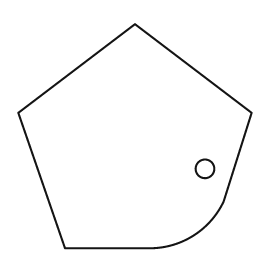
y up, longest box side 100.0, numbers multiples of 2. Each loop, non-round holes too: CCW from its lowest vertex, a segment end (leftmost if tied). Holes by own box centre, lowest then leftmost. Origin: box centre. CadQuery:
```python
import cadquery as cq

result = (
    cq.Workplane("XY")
    .moveTo(-30.0, -48.0)
    .lineTo(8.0, -48.0)
    .threePointArc((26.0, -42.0), (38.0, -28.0))
    .lineTo(50.0, 10.0)
    .lineTo(0.0, 48.0)
    .lineTo(-50.0, 10.0)
    .close()
    .moveTo(30.0, -14.0)
    .circle(4.0)
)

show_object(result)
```